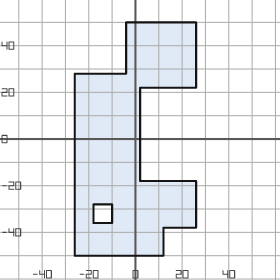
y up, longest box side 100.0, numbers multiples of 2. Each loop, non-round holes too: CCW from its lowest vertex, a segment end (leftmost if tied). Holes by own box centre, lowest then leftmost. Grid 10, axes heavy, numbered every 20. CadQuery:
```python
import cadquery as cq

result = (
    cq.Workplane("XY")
    .moveTo(-26.0, -50.0)
    .lineTo(12.0, -50.0)
    .lineTo(12.0, -38.0)
    .lineTo(26.0, -38.0)
    .lineTo(26.0, -18.0)
    .lineTo(2.0, -18.0)
    .lineTo(2.0, 22.0)
    .lineTo(26.0, 22.0)
    .lineTo(26.0, 50.0)
    .lineTo(-4.0, 50.0)
    .lineTo(-4.0, 28.0)
    .lineTo(-26.0, 28.0)
    .close()
    .moveTo(-18.0, -36.0)
    .lineTo(-10.0, -36.0)
    .lineTo(-10.0, -28.0)
    .lineTo(-18.0, -28.0)
    .close()
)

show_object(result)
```